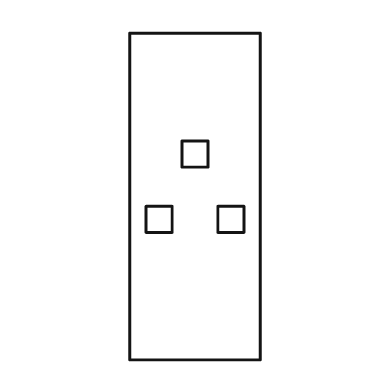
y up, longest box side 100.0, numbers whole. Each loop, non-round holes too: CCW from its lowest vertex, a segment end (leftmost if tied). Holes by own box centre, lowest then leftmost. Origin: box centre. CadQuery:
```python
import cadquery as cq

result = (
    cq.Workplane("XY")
    .moveTo(-20.0, -50.0)
    .lineTo(20.0, -50.0)
    .lineTo(20.0, 50.0)
    .lineTo(-20.0, 50.0)
    .close()
    .moveTo(-15.0, -11.0)
    .lineTo(-7.0, -11.0)
    .lineTo(-7.0, -3.0)
    .lineTo(-15.0, -3.0)
    .close()
    .moveTo(7.0, -11.0)
    .lineTo(15.0, -11.0)
    .lineTo(15.0, -3.0)
    .lineTo(7.0, -3.0)
    .close()
    .moveTo(-4.0, 9.0)
    .lineTo(4.0, 9.0)
    .lineTo(4.0, 17.0)
    .lineTo(-4.0, 17.0)
    .close()
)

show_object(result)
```